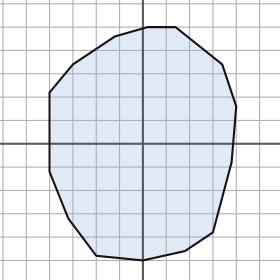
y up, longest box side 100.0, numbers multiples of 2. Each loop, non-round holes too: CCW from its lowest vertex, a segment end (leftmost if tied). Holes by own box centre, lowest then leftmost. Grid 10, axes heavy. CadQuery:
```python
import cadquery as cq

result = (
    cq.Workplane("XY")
    .moveTo(0.0, -50.0)
    .lineTo(18.0, -46.0)
    .lineTo(30.0, -38.0)
    .lineTo(38.0, -8.0)
    .lineTo(40.0, 16.0)
    .lineTo(34.0, 34.0)
    .lineTo(14.0, 50.0)
    .lineTo(2.0, 50.0)
    .lineTo(-12.0, 46.0)
    .lineTo(-30.0, 34.0)
    .lineTo(-40.0, 22.0)
    .lineTo(-40.0, -12.0)
    .lineTo(-32.0, -32.0)
    .lineTo(-20.0, -48.0)
    .close()
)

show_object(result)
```